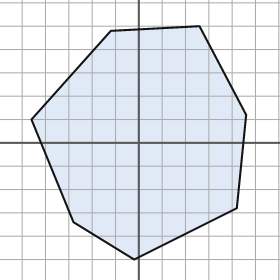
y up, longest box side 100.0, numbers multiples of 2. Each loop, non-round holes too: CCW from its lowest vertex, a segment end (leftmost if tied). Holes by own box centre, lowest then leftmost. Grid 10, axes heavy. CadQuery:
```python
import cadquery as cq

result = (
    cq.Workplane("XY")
    .moveTo(-2.0, -50.0)
    .lineTo(42.0, -28.0)
    .lineTo(46.0, 12.0)
    .lineTo(26.0, 50.0)
    .lineTo(-12.0, 48.0)
    .lineTo(-46.0, 10.0)
    .lineTo(-28.0, -34.0)
    .close()
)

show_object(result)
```